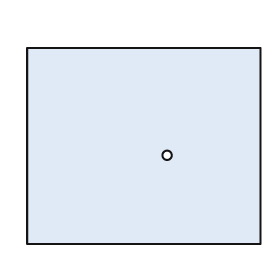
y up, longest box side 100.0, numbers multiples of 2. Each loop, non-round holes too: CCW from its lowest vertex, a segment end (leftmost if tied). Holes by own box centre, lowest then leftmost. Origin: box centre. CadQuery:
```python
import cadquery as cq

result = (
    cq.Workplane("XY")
    .moveTo(-50.0, -42.0)
    .lineTo(50.0, -42.0)
    .lineTo(50.0, 42.0)
    .lineTo(-50.0, 42.0)
    .close()
    .moveTo(10.0, -4.0)
    .circle(2.0)
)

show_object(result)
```